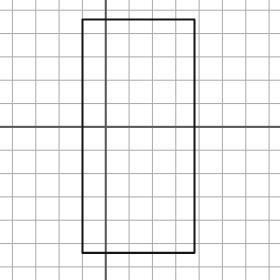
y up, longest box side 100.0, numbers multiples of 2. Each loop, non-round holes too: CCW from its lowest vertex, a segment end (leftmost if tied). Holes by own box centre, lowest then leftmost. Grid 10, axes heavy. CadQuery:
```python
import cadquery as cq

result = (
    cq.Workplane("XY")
    .moveTo(-10.0, -54.0)
    .lineTo(38.0, -54.0)
    .lineTo(38.0, 46.0)
    .lineTo(-10.0, 46.0)
    .close()
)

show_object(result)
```